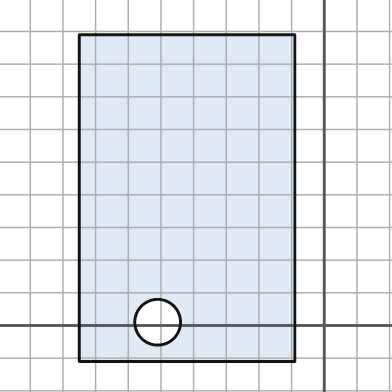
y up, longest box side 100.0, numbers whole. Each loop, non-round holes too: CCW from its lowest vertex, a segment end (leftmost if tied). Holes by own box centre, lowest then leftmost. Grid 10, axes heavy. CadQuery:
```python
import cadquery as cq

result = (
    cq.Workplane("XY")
    .moveTo(-75.0, -11.0)
    .lineTo(-9.0, -11.0)
    .lineTo(-9.0, 89.0)
    .lineTo(-75.0, 89.0)
    .close()
    .moveTo(-51.0, 1.0)
    .circle(7.0)
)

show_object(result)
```